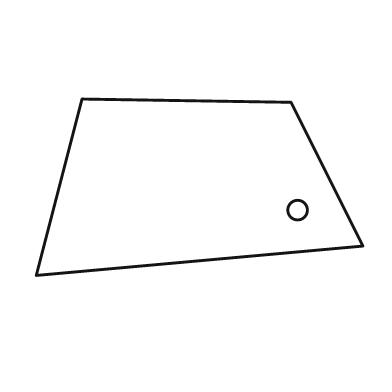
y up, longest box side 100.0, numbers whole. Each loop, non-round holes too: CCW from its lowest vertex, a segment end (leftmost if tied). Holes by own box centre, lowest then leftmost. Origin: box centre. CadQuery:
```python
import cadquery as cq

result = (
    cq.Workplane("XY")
    .moveTo(-50.0, -27.0)
    .lineTo(50.0, -18.0)
    .lineTo(28.0, 26.0)
    .lineTo(-36.0, 27.0)
    .close()
    .moveTo(30.0, -7.0)
    .circle(3.0)
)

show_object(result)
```